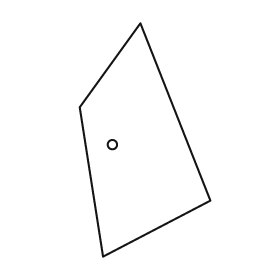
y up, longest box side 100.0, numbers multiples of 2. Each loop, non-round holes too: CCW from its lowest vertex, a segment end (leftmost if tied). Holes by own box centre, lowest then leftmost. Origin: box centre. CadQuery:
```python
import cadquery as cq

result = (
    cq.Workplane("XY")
    .moveTo(-18.0, -50.0)
    .lineTo(28.0, -26.0)
    .lineTo(-2.0, 50.0)
    .lineTo(-28.0, 14.0)
    .close()
    .moveTo(-14.0, -2.0)
    .circle(2.0)
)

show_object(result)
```